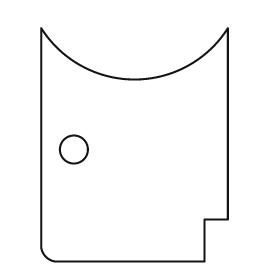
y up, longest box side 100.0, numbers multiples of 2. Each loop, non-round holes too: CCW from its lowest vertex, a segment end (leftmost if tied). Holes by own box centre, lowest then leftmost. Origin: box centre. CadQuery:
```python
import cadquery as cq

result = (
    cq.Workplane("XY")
    .moveTo(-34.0, -50.0)
    .lineTo(30.0, -50.0)
    .lineTo(30.0, -32.0)
    .lineTo(40.0, -32.0)
    .lineTo(40.0, 50.0)
    .threePointArc((0.0, 28.0), (-40.0, 50.0))
    .lineTo(-40.0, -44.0)
    .threePointArc((-38.0, -48.0), (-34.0, -50.0))
    .close()
    .moveTo(-26.0, -2.0)
    .circle(6.0)
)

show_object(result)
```